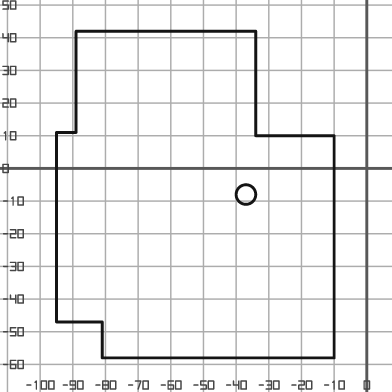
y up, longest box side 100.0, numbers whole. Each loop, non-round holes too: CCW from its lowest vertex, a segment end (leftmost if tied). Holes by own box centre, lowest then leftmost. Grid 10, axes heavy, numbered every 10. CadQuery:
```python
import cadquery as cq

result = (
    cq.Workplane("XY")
    .moveTo(-81.0, -58.0)
    .lineTo(-10.0, -58.0)
    .lineTo(-10.0, 10.0)
    .lineTo(-34.0, 10.0)
    .lineTo(-34.0, 42.0)
    .lineTo(-89.0, 42.0)
    .lineTo(-89.0, 11.0)
    .lineTo(-95.0, 11.0)
    .lineTo(-95.0, -47.0)
    .lineTo(-81.0, -47.0)
    .close()
    .moveTo(-37.0, -8.0)
    .circle(3.0)
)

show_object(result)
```